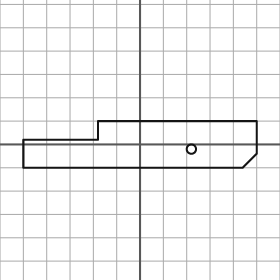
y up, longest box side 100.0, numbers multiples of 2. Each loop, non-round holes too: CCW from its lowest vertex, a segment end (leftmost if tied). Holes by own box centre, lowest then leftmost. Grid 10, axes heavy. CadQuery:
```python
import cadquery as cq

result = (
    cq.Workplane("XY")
    .moveTo(-50.0, -10.0)
    .lineTo(44.0, -10.0)
    .lineTo(50.0, -4.0)
    .lineTo(50.0, 10.0)
    .lineTo(-18.0, 10.0)
    .lineTo(-18.0, 2.0)
    .lineTo(-50.0, 2.0)
    .close()
    .moveTo(22.0, -2.0)
    .circle(2.0)
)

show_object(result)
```